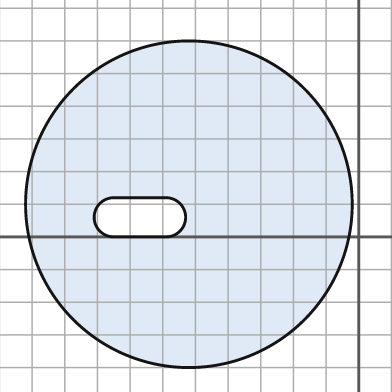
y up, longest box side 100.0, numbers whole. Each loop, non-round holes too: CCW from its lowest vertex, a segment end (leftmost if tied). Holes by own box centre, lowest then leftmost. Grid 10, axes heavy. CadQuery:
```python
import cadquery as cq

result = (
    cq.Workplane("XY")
    .moveTo(-52.0, 10.0)
    .circle(50.0)
    .moveTo(-75.0, 0.0)
    .lineTo(-59.0, 0.0)
    .threePointArc((-53.0, 6.0), (-59.0, 12.0))
    .lineTo(-75.0, 12.0)
    .threePointArc((-81.0, 6.0), (-75.0, 0.0))
    .close()
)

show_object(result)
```